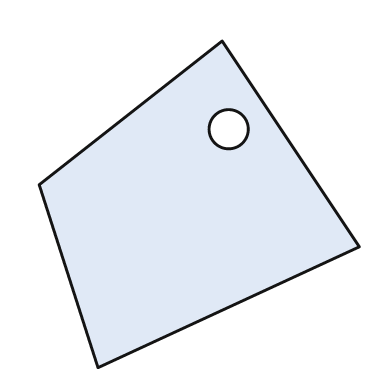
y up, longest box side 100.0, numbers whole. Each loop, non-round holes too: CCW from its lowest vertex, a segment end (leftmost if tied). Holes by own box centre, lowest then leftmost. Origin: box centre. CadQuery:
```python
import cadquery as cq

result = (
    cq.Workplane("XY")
    .moveTo(-31.0, -50.0)
    .lineTo(49.0, -13.0)
    .lineTo(7.0, 50.0)
    .lineTo(-49.0, 6.0)
    .close()
    .moveTo(9.0, 23.0)
    .circle(6.0)
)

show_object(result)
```